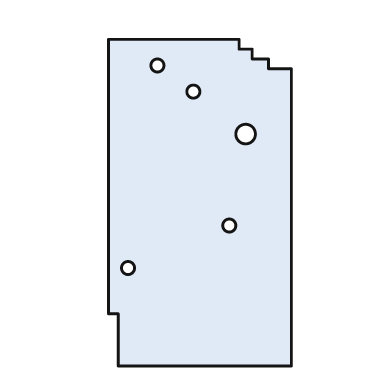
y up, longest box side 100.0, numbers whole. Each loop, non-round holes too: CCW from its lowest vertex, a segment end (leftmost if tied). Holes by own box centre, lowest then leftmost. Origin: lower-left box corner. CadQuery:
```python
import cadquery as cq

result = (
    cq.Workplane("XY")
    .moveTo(3.0, 0.0)
    .lineTo(56.0, 0.0)
    .lineTo(56.0, 91.0)
    .lineTo(49.0, 91.0)
    .lineTo(49.0, 94.0)
    .lineTo(44.0, 94.0)
    .lineTo(44.0, 97.0)
    .lineTo(40.0, 97.0)
    .lineTo(40.0, 100.0)
    .lineTo(0.0, 100.0)
    .lineTo(0.0, 16.0)
    .lineTo(3.0, 16.0)
    .close()
    .moveTo(6.0, 30.0)
    .circle(2.0)
    .moveTo(37.0, 43.0)
    .circle(2.0)
    .moveTo(42.0, 71.0)
    .circle(3.0)
    .moveTo(26.0, 84.0)
    .circle(2.0)
    .moveTo(15.0, 92.0)
    .circle(2.0)
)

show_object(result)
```